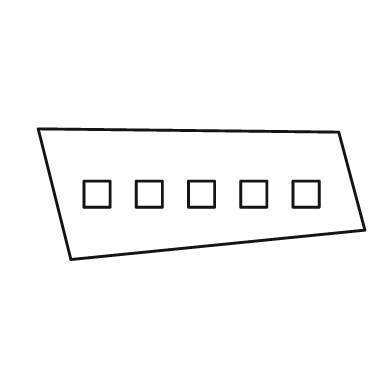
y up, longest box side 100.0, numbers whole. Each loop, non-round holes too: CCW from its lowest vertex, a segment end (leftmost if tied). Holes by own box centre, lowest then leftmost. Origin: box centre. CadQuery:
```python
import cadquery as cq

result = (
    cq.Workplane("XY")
    .moveTo(-40.0, -20.0)
    .lineTo(50.0, -11.0)
    .lineTo(42.0, 19.0)
    .lineTo(-50.0, 20.0)
    .close()
    .moveTo(-36.0, -4.0)
    .lineTo(-28.0, -4.0)
    .lineTo(-28.0, 4.0)
    .lineTo(-36.0, 4.0)
    .close()
    .moveTo(-20.0, -4.0)
    .lineTo(-12.0, -4.0)
    .lineTo(-12.0, 4.0)
    .lineTo(-20.0, 4.0)
    .close()
    .moveTo(-4.0, -4.0)
    .lineTo(4.0, -4.0)
    .lineTo(4.0, 4.0)
    .lineTo(-4.0, 4.0)
    .close()
    .moveTo(12.0, -4.0)
    .lineTo(20.0, -4.0)
    .lineTo(20.0, 4.0)
    .lineTo(12.0, 4.0)
    .close()
    .moveTo(28.0, -4.0)
    .lineTo(36.0, -4.0)
    .lineTo(36.0, 4.0)
    .lineTo(28.0, 4.0)
    .close()
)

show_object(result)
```